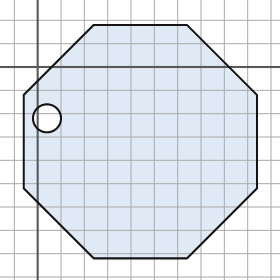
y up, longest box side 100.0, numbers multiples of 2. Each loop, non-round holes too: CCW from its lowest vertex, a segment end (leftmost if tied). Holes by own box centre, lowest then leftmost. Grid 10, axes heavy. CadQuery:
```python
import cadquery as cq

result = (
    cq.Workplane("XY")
    .moveTo(24.0, -82.0)
    .lineTo(64.0, -82.0)
    .lineTo(94.0, -52.0)
    .lineTo(94.0, -12.0)
    .lineTo(64.0, 18.0)
    .lineTo(24.0, 18.0)
    .lineTo(-6.0, -12.0)
    .lineTo(-6.0, -52.0)
    .close()
    .moveTo(4.0, -22.0)
    .circle(6.0)
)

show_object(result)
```